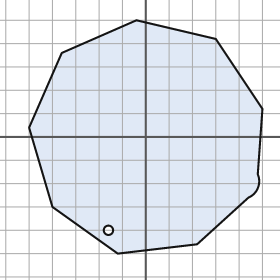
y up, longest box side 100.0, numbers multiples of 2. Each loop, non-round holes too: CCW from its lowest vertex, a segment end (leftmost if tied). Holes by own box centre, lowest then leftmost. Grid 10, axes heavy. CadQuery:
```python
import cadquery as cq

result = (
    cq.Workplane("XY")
    .moveTo(-12.0, -50.0)
    .lineTo(22.0, -46.0)
    .lineTo(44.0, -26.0)
    .threePointArc((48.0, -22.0), (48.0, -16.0))
    .lineTo(50.0, 12.0)
    .lineTo(30.0, 42.0)
    .lineTo(-4.0, 50.0)
    .lineTo(-36.0, 36.0)
    .lineTo(-50.0, 4.0)
    .lineTo(-40.0, -30.0)
    .close()
    .moveTo(-16.0, -40.0)
    .circle(2.0)
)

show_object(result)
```